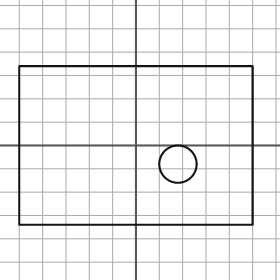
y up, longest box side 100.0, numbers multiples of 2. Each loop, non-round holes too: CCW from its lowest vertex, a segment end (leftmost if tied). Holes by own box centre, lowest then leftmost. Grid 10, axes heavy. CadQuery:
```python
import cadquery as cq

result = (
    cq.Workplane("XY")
    .moveTo(-50.0, -34.0)
    .lineTo(50.0, -34.0)
    .lineTo(50.0, 34.0)
    .lineTo(-50.0, 34.0)
    .close()
    .moveTo(18.0, -8.0)
    .circle(8.0)
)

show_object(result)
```